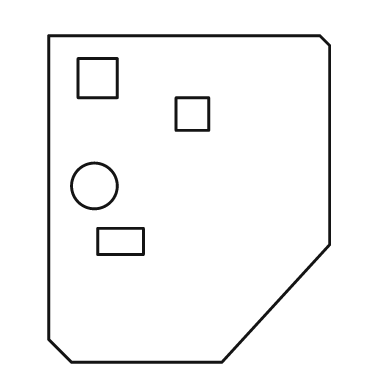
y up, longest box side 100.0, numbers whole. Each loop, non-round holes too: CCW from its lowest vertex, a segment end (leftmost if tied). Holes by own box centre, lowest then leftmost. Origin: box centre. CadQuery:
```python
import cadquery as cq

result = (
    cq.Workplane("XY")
    .moveTo(-36.0, -50.0)
    .lineTo(10.0, -50.0)
    .lineTo(43.0, -14.0)
    .lineTo(43.0, 47.0)
    .lineTo(40.0, 50.0)
    .lineTo(-43.0, 50.0)
    .lineTo(-43.0, -43.0)
    .close()
    .moveTo(-28.0, -17.0)
    .lineTo(-14.0, -17.0)
    .lineTo(-14.0, -9.0)
    .lineTo(-28.0, -9.0)
    .close()
    .moveTo(-29.0, 4.0)
    .circle(7.0)
    .moveTo(-4.0, 21.0)
    .lineTo(6.0, 21.0)
    .lineTo(6.0, 31.0)
    .lineTo(-4.0, 31.0)
    .close()
    .moveTo(-34.0, 31.0)
    .lineTo(-22.0, 31.0)
    .lineTo(-22.0, 43.0)
    .lineTo(-34.0, 43.0)
    .close()
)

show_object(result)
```